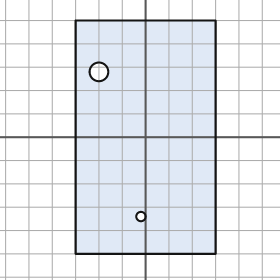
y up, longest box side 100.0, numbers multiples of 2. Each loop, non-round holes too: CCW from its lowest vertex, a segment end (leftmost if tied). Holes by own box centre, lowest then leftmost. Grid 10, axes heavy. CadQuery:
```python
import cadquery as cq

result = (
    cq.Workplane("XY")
    .moveTo(-30.0, -50.0)
    .lineTo(30.0, -50.0)
    .lineTo(30.0, 50.0)
    .lineTo(-30.0, 50.0)
    .close()
    .moveTo(-2.0, -34.0)
    .circle(2.0)
    .moveTo(-20.0, 28.0)
    .circle(4.0)
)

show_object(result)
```